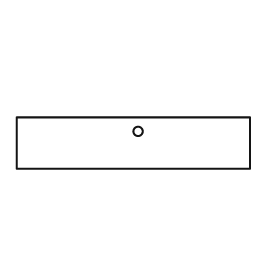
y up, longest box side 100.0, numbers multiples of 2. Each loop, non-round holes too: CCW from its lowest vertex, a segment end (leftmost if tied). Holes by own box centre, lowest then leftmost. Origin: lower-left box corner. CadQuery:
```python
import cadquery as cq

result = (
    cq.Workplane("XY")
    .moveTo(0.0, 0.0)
    .lineTo(100.0, 0.0)
    .lineTo(100.0, 22.0)
    .lineTo(0.0, 22.0)
    .close()
    .moveTo(52.0, 16.0)
    .circle(2.0)
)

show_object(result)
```